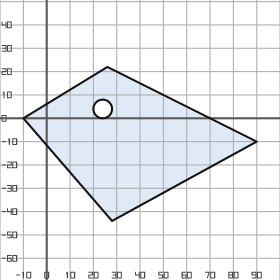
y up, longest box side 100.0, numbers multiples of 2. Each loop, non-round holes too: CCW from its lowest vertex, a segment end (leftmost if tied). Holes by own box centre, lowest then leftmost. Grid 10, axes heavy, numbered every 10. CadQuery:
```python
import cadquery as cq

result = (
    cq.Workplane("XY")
    .moveTo(28.0, -44.0)
    .lineTo(90.0, -10.0)
    .lineTo(26.0, 22.0)
    .lineTo(-10.0, 0.0)
    .close()
    .moveTo(24.0, 4.0)
    .circle(4.0)
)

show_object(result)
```